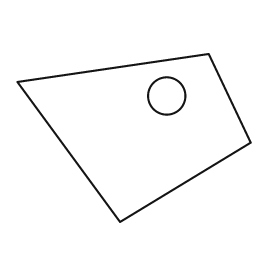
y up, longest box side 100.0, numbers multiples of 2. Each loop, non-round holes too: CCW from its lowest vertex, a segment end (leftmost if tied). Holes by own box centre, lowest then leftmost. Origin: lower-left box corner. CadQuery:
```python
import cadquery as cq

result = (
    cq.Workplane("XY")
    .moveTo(44.0, 0.0)
    .lineTo(100.0, 34.0)
    .lineTo(82.0, 72.0)
    .lineTo(0.0, 60.0)
    .close()
    .moveTo(64.0, 54.0)
    .circle(8.0)
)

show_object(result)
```